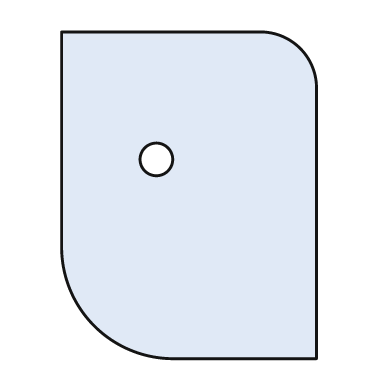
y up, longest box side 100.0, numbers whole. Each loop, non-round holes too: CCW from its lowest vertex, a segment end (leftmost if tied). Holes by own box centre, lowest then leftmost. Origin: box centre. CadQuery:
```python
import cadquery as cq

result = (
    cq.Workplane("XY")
    .moveTo(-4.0, -50.0)
    .lineTo(39.0, -50.0)
    .lineTo(39.0, 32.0)
    .threePointArc((34.0, 45.0), (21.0, 50.0))
    .lineTo(-39.0, 50.0)
    .lineTo(-39.0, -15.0)
    .threePointArc((-29.0, -40.0), (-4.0, -50.0))
    .close()
    .moveTo(-10.0, 11.0)
    .circle(5.0)
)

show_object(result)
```